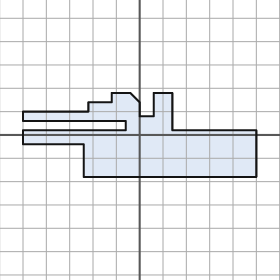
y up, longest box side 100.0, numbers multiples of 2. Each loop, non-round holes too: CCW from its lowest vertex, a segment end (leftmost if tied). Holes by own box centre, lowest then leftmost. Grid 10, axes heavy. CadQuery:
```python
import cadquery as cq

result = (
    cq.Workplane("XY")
    .moveTo(-24.0, -18.0)
    .lineTo(50.0, -18.0)
    .lineTo(50.0, 2.0)
    .lineTo(14.0, 2.0)
    .lineTo(14.0, 18.0)
    .lineTo(6.0, 18.0)
    .lineTo(6.0, 8.0)
    .lineTo(0.0, 8.0)
    .lineTo(0.0, 14.0)
    .lineTo(-4.0, 18.0)
    .lineTo(-12.0, 18.0)
    .lineTo(-12.0, 14.0)
    .lineTo(-22.0, 14.0)
    .lineTo(-22.0, 10.0)
    .lineTo(-50.0, 10.0)
    .lineTo(-50.0, 6.0)
    .lineTo(-6.0, 6.0)
    .lineTo(-6.0, 2.0)
    .lineTo(-50.0, 2.0)
    .lineTo(-50.0, -4.0)
    .lineTo(-24.0, -4.0)
    .close()
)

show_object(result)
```